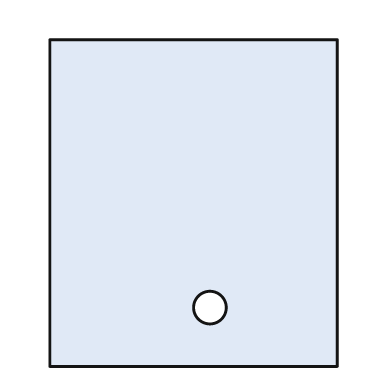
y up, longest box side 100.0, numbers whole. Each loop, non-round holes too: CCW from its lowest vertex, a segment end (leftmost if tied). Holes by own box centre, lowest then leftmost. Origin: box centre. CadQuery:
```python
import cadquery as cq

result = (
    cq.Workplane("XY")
    .moveTo(-44.0, -50.0)
    .lineTo(44.0, -50.0)
    .lineTo(44.0, 50.0)
    .lineTo(-44.0, 50.0)
    .close()
    .moveTo(5.0, -32.0)
    .circle(5.0)
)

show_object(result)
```